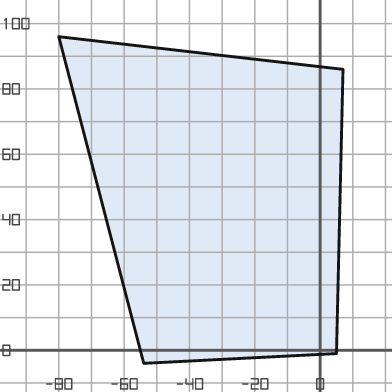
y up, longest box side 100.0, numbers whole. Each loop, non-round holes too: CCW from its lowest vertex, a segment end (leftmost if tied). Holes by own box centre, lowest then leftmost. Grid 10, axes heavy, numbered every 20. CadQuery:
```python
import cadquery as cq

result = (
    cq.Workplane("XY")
    .moveTo(-54.0, -4.0)
    .lineTo(5.0, -1.0)
    .lineTo(7.0, 86.0)
    .lineTo(-80.0, 96.0)
    .close()
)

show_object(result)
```